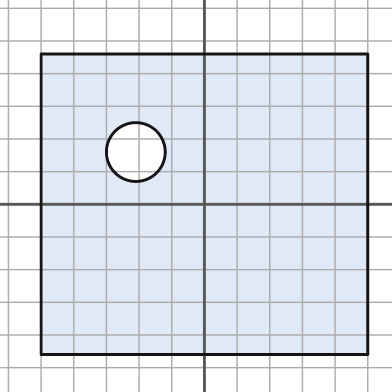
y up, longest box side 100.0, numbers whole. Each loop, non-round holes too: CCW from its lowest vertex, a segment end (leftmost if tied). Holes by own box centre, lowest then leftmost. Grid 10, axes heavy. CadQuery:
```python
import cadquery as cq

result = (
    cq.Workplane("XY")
    .moveTo(-50.0, -46.0)
    .lineTo(50.0, -46.0)
    .lineTo(50.0, 46.0)
    .lineTo(-50.0, 46.0)
    .close()
    .moveTo(-21.0, 16.0)
    .circle(9.0)
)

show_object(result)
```